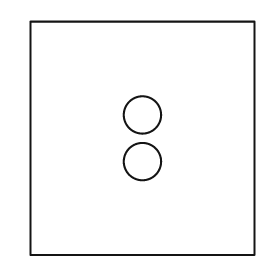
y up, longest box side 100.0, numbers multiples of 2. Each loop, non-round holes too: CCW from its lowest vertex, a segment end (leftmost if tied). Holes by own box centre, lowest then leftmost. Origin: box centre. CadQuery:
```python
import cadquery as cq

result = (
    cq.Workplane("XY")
    .moveTo(-48.0, -50.0)
    .lineTo(48.0, -50.0)
    .lineTo(48.0, 50.0)
    .lineTo(-48.0, 50.0)
    .close()
    .moveTo(0.0, -10.0)
    .circle(8.0)
    .moveTo(0.0, 10.0)
    .circle(8.0)
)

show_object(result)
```